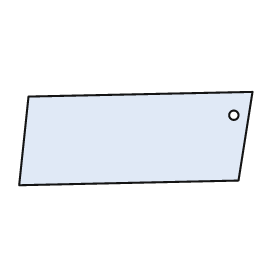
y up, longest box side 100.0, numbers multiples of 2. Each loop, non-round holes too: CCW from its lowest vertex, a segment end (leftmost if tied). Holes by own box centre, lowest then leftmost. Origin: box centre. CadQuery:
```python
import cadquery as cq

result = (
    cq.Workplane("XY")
    .moveTo(-50.0, -20.0)
    .lineTo(44.0, -18.0)
    .lineTo(50.0, 20.0)
    .lineTo(-46.0, 18.0)
    .close()
    .moveTo(42.0, 10.0)
    .circle(2.0)
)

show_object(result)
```